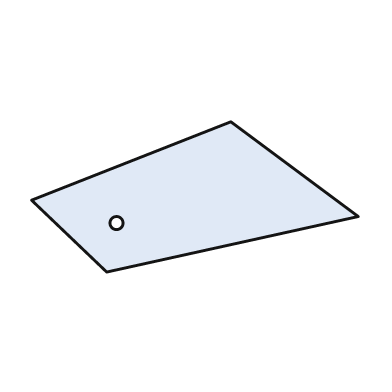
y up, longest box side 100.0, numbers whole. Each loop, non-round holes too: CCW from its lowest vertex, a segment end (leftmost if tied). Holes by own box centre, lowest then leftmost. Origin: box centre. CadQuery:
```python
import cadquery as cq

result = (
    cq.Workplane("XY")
    .moveTo(-27.0, -23.0)
    .lineTo(50.0, -6.0)
    .lineTo(11.0, 23.0)
    .lineTo(-50.0, -1.0)
    .close()
    .moveTo(-24.0, -8.0)
    .circle(2.0)
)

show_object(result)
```